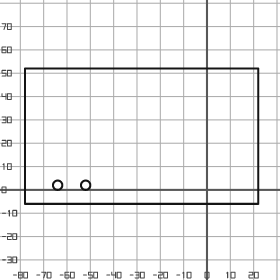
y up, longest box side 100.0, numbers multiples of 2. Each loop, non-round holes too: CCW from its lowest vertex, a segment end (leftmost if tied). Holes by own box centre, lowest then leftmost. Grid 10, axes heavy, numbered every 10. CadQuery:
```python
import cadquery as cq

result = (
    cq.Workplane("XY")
    .moveTo(-78.0, -6.0)
    .lineTo(22.0, -6.0)
    .lineTo(22.0, 52.0)
    .lineTo(-78.0, 52.0)
    .close()
    .moveTo(-64.0, 2.0)
    .circle(2.0)
    .moveTo(-52.0, 2.0)
    .circle(2.0)
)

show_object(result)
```